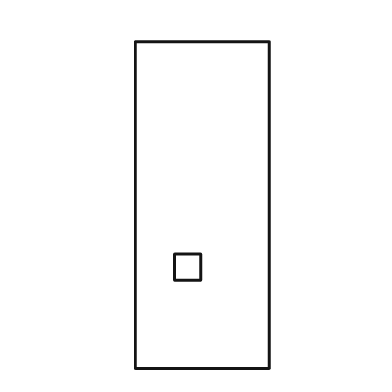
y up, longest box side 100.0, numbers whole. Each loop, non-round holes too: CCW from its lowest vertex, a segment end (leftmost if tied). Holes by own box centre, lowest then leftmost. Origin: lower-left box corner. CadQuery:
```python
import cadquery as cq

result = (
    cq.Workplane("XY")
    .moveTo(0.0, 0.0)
    .lineTo(41.0, 0.0)
    .lineTo(41.0, 100.0)
    .lineTo(0.0, 100.0)
    .close()
    .moveTo(12.0, 27.0)
    .lineTo(20.0, 27.0)
    .lineTo(20.0, 35.0)
    .lineTo(12.0, 35.0)
    .close()
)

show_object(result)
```